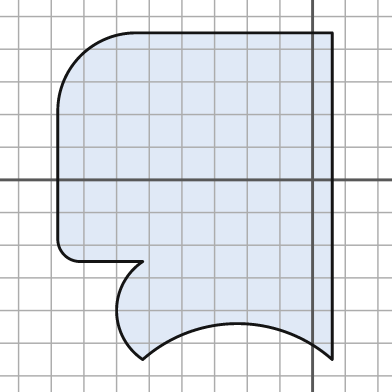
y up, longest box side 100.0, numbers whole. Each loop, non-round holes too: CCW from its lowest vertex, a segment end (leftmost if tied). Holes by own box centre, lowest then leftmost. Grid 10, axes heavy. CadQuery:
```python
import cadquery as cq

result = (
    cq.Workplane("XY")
    .moveTo(-52.0, -55.0)
    .threePointArc((-23.0, -44.0), (6.0, -55.0))
    .lineTo(6.0, 45.0)
    .lineTo(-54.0, 45.0)
    .threePointArc((-71.0, 38.0), (-78.0, 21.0))
    .lineTo(-78.0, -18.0)
    .threePointArc((-76.0, -23.0), (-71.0, -25.0))
    .lineTo(-52.0, -25.0)
    .threePointArc((-60.0, -40.0), (-52.0, -55.0))
    .close()
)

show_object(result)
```